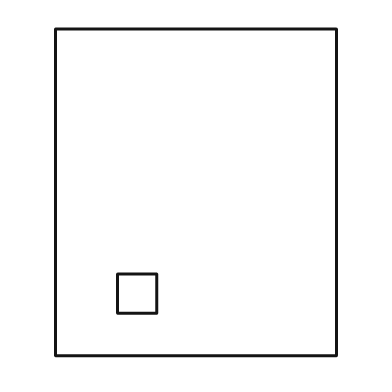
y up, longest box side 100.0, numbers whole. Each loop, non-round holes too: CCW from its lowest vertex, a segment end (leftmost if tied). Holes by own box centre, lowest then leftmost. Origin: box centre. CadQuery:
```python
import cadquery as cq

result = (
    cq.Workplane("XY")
    .moveTo(-43.0, -50.0)
    .lineTo(43.0, -50.0)
    .lineTo(43.0, 50.0)
    .lineTo(-43.0, 50.0)
    .close()
    .moveTo(-24.0, -37.0)
    .lineTo(-12.0, -37.0)
    .lineTo(-12.0, -25.0)
    .lineTo(-24.0, -25.0)
    .close()
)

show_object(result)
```